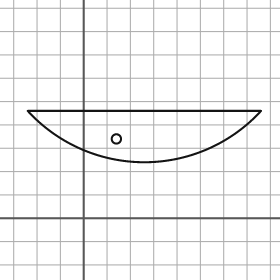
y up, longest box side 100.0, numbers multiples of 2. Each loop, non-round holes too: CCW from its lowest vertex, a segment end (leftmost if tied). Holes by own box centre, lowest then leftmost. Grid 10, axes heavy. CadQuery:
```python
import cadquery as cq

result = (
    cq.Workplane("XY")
    .moveTo(-24.0, 46.0)
    .threePointArc((26.0, 24.0), (76.0, 46.0))
    .close()
    .moveTo(14.0, 34.0)
    .circle(2.0)
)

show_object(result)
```